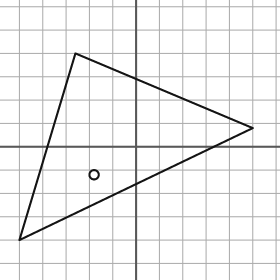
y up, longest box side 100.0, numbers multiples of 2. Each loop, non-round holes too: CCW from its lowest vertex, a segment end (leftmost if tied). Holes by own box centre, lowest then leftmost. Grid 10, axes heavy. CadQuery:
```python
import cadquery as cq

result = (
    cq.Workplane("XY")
    .moveTo(-50.0, -40.0)
    .lineTo(50.0, 8.0)
    .lineTo(-26.0, 40.0)
    .close()
    .moveTo(-18.0, -12.0)
    .circle(2.0)
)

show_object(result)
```